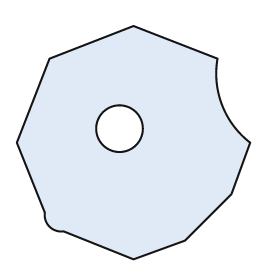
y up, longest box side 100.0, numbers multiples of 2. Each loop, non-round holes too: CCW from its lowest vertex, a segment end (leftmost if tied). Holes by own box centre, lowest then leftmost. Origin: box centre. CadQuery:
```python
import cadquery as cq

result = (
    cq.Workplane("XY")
    .moveTo(0.0, -50.0)
    .lineTo(22.0, -42.0)
    .lineTo(42.0, -22.0)
    .lineTo(50.0, 0.0)
    .threePointArc((38.0, 16.0), (36.0, 36.0))
    .lineTo(0.0, 50.0)
    .lineTo(-36.0, 36.0)
    .lineTo(-50.0, 0.0)
    .lineTo(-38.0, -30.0)
    .threePointArc((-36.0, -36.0), (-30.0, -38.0))
    .close()
    .moveTo(-6.0, 6.0)
    .circle(10.0)
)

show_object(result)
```